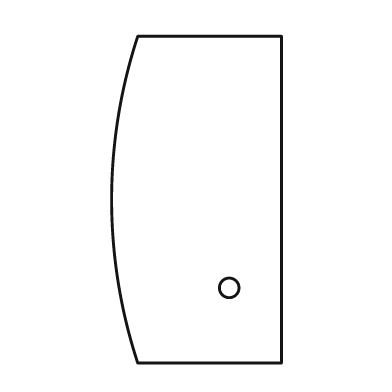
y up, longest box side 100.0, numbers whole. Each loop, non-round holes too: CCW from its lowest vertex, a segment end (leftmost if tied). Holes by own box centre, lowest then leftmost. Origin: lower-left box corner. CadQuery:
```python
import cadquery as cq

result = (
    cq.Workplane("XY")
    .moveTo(8.0, 0.0)
    .lineTo(52.0, 0.0)
    .lineTo(52.0, 100.0)
    .lineTo(8.0, 100.0)
    .threePointArc((0.0, 50.0), (8.0, 0.0))
    .close()
    .moveTo(36.0, 23.0)
    .circle(3.0)
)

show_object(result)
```